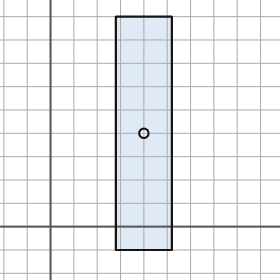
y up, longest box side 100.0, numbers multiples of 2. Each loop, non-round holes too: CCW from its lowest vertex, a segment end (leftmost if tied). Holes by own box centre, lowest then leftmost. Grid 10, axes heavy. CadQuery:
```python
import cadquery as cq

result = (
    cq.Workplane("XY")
    .moveTo(28.0, -10.0)
    .lineTo(52.0, -10.0)
    .lineTo(52.0, 90.0)
    .lineTo(28.0, 90.0)
    .close()
    .moveTo(40.0, 40.0)
    .circle(2.0)
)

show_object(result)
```